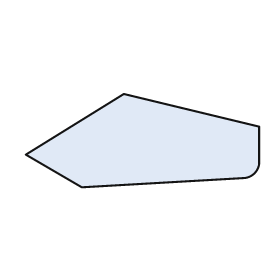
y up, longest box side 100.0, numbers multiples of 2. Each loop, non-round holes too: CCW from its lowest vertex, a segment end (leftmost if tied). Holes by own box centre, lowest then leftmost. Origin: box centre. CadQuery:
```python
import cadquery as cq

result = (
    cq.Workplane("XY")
    .moveTo(-26.0, -20.0)
    .lineTo(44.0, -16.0)
    .threePointArc((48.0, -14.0), (50.0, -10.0))
    .lineTo(50.0, 6.0)
    .lineTo(-8.0, 20.0)
    .lineTo(-50.0, -6.0)
    .close()
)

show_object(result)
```